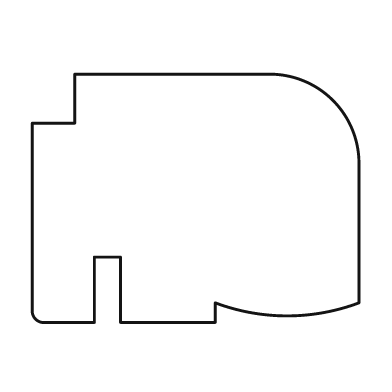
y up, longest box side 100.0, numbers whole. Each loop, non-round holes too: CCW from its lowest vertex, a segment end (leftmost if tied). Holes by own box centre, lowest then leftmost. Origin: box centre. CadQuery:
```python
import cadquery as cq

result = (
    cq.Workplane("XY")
    .moveTo(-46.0, -38.0)
    .lineTo(-31.0, -38.0)
    .lineTo(-31.0, -18.0)
    .lineTo(-23.0, -18.0)
    .lineTo(-23.0, -38.0)
    .lineTo(6.0, -38.0)
    .lineTo(6.0, -32.0)
    .threePointArc((28.0, -36.0), (50.0, -32.0))
    .lineTo(50.0, 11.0)
    .threePointArc((42.0, 30.0), (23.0, 38.0))
    .lineTo(-37.0, 38.0)
    .lineTo(-37.0, 23.0)
    .lineTo(-50.0, 23.0)
    .lineTo(-50.0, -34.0)
    .threePointArc((-49.0, -37.0), (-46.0, -38.0))
    .close()
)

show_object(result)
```